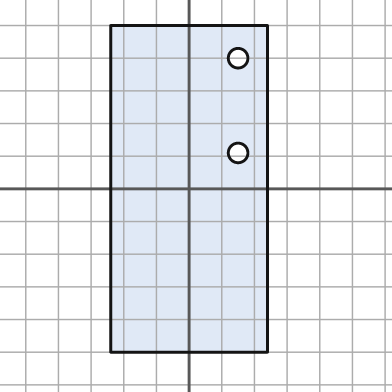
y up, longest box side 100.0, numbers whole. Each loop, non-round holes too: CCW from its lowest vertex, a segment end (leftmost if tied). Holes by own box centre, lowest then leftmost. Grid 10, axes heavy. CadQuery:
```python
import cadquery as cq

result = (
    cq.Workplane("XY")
    .moveTo(-24.0, -50.0)
    .lineTo(24.0, -50.0)
    .lineTo(24.0, 50.0)
    .lineTo(-24.0, 50.0)
    .close()
    .moveTo(15.0, 11.0)
    .circle(3.0)
    .moveTo(15.0, 40.0)
    .circle(3.0)
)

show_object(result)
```